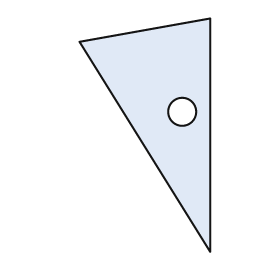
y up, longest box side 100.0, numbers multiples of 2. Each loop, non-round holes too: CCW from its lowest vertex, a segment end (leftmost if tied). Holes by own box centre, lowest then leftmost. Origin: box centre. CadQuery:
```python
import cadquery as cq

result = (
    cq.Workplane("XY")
    .moveTo(28.0, -50.0)
    .lineTo(28.0, 50.0)
    .lineTo(-28.0, 40.0)
    .close()
    .moveTo(16.0, 10.0)
    .circle(6.0)
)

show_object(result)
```